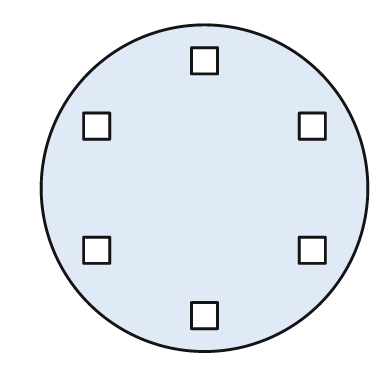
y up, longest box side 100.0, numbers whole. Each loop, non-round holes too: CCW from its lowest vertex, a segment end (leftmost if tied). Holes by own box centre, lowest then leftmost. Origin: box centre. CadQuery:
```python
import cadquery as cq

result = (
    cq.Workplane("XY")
    .moveTo(0.0, 0.0)
    .circle(50.0)
    .moveTo(-4.0, -43.0)
    .lineTo(4.0, -43.0)
    .lineTo(4.0, -35.0)
    .lineTo(-4.0, -35.0)
    .close()
    .moveTo(-37.0, -23.0)
    .lineTo(-29.0, -23.0)
    .lineTo(-29.0, -15.0)
    .lineTo(-37.0, -15.0)
    .close()
    .moveTo(29.0, -23.0)
    .lineTo(37.0, -23.0)
    .lineTo(37.0, -15.0)
    .lineTo(29.0, -15.0)
    .close()
    .moveTo(-37.0, 15.0)
    .lineTo(-29.0, 15.0)
    .lineTo(-29.0, 23.0)
    .lineTo(-37.0, 23.0)
    .close()
    .moveTo(29.0, 15.0)
    .lineTo(37.0, 15.0)
    .lineTo(37.0, 23.0)
    .lineTo(29.0, 23.0)
    .close()
    .moveTo(-4.0, 35.0)
    .lineTo(4.0, 35.0)
    .lineTo(4.0, 43.0)
    .lineTo(-4.0, 43.0)
    .close()
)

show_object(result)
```